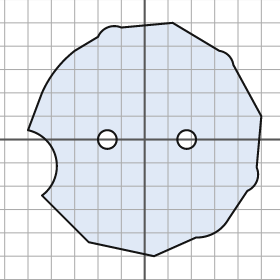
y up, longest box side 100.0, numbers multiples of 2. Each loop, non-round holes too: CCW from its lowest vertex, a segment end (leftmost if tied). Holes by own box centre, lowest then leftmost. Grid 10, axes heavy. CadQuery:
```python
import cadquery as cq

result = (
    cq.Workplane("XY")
    .moveTo(4.0, -50.0)
    .lineTo(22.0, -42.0)
    .threePointArc((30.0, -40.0), (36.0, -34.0))
    .lineTo(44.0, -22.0)
    .threePointArc((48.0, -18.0), (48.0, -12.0))
    .lineTo(50.0, 10.0)
    .lineTo(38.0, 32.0)
    .threePointArc((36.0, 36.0), (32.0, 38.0))
    .lineTo(12.0, 50.0)
    .lineTo(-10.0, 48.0)
    .threePointArc((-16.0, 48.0), (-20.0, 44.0))
    .lineTo(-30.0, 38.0)
    .threePointArc((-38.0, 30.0), (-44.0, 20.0))
    .lineTo(-50.0, 4.0)
    .threePointArc((-38.0, -8.0), (-44.0, -24.0))
    .lineTo(-24.0, -44.0)
    .close()
    .moveTo(-16.0, 0.0)
    .circle(4.0)
    .moveTo(18.0, 0.0)
    .circle(4.0)
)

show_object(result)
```